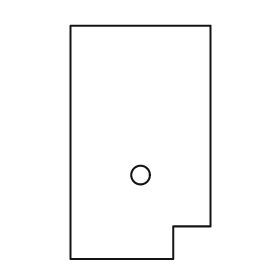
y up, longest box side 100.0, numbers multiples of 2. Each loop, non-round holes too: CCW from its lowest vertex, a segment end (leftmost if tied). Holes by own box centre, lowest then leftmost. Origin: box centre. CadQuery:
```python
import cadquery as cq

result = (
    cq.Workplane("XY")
    .moveTo(-30.0, -50.0)
    .lineTo(14.0, -50.0)
    .lineTo(14.0, -36.0)
    .lineTo(30.0, -36.0)
    .lineTo(30.0, 50.0)
    .lineTo(-30.0, 50.0)
    .close()
    .moveTo(0.0, -14.0)
    .circle(4.0)
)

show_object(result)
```